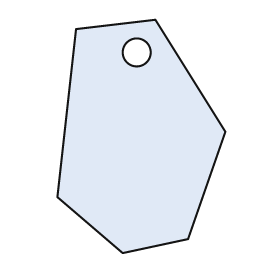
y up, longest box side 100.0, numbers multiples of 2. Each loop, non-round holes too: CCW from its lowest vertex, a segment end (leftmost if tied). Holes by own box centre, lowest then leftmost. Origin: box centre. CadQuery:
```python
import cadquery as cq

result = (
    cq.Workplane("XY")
    .moveTo(-8.0, -50.0)
    .lineTo(20.0, -44.0)
    .lineTo(36.0, 2.0)
    .lineTo(6.0, 50.0)
    .lineTo(-28.0, 46.0)
    .lineTo(-36.0, -26.0)
    .close()
    .moveTo(-2.0, 36.0)
    .circle(6.0)
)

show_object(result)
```